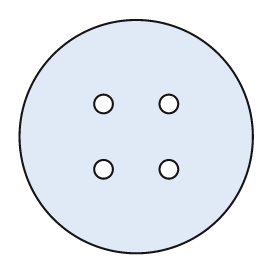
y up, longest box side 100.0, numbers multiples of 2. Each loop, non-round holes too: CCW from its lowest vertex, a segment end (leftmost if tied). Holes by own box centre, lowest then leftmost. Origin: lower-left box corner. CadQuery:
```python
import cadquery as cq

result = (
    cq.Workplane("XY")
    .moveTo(50.0, 50.0)
    .circle(50.0)
    .moveTo(36.0, 36.0)
    .circle(4.0)
    .moveTo(64.0, 36.0)
    .circle(4.0)
    .moveTo(36.0, 64.0)
    .circle(4.0)
    .moveTo(64.0, 64.0)
    .circle(4.0)
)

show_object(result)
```